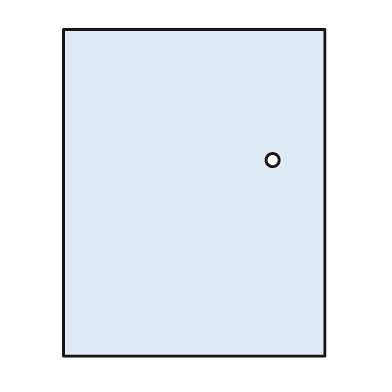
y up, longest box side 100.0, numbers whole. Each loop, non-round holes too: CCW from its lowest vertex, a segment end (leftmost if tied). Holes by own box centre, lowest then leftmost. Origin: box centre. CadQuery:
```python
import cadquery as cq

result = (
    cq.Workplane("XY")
    .moveTo(-40.0, -50.0)
    .lineTo(40.0, -50.0)
    .lineTo(40.0, 50.0)
    .lineTo(-40.0, 50.0)
    .close()
    .moveTo(24.0, 10.0)
    .circle(2.0)
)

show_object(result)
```